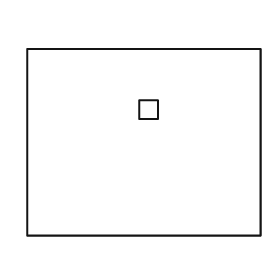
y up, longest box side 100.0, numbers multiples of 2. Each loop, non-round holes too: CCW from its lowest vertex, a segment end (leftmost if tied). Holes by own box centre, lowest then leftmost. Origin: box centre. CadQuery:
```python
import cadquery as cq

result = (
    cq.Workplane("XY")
    .moveTo(-50.0, -40.0)
    .lineTo(50.0, -40.0)
    .lineTo(50.0, 40.0)
    .lineTo(-50.0, 40.0)
    .close()
    .moveTo(-2.0, 10.0)
    .lineTo(6.0, 10.0)
    .lineTo(6.0, 18.0)
    .lineTo(-2.0, 18.0)
    .close()
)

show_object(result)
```